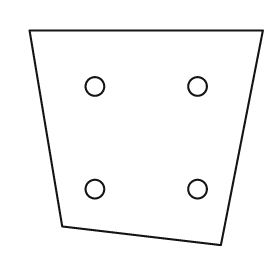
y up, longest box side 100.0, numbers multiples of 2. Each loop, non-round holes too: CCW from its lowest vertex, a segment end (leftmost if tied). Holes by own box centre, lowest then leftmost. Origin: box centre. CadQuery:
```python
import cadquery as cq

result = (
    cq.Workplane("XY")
    .moveTo(32.0, -46.0)
    .lineTo(50.0, 46.0)
    .lineTo(-50.0, 46.0)
    .lineTo(-36.0, -38.0)
    .close()
    .moveTo(-22.0, -22.0)
    .circle(4.0)
    .moveTo(22.0, -22.0)
    .circle(4.0)
    .moveTo(-22.0, 22.0)
    .circle(4.0)
    .moveTo(22.0, 22.0)
    .circle(4.0)
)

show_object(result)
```